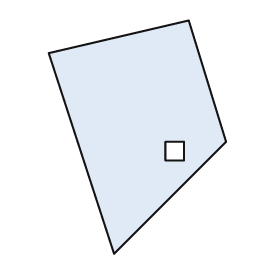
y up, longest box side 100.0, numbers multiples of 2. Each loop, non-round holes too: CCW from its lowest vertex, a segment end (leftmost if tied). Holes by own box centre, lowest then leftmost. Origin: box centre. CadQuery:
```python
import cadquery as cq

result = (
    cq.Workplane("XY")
    .moveTo(-10.0, -50.0)
    .lineTo(38.0, -2.0)
    .lineTo(22.0, 50.0)
    .lineTo(-38.0, 36.0)
    .close()
    .moveTo(12.0, -10.0)
    .lineTo(20.0, -10.0)
    .lineTo(20.0, -2.0)
    .lineTo(12.0, -2.0)
    .close()
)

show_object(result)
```